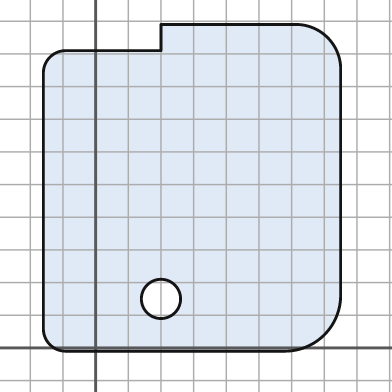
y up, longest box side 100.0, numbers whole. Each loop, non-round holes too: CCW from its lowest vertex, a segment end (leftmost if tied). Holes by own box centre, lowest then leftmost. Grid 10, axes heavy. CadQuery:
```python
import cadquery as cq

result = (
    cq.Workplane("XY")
    .moveTo(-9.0, -1.0)
    .lineTo(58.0, -1.0)
    .threePointArc((70.0, 4.0), (75.0, 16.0))
    .lineTo(75.0, 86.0)
    .threePointArc((71.0, 95.0), (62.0, 99.0))
    .lineTo(20.0, 99.0)
    .lineTo(20.0, 91.0)
    .lineTo(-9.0, 91.0)
    .threePointArc((-14.0, 89.0), (-16.0, 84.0))
    .lineTo(-16.0, 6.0)
    .threePointArc((-14.0, 1.0), (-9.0, -1.0))
    .close()
    .moveTo(20.0, 15.0)
    .circle(6.0)
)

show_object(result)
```